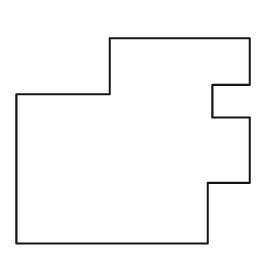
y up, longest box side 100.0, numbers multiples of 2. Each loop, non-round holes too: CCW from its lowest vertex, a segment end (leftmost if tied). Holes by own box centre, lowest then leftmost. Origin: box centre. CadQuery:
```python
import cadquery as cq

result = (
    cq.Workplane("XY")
    .moveTo(-50.0, -44.0)
    .lineTo(32.0, -44.0)
    .lineTo(32.0, -18.0)
    .lineTo(50.0, -18.0)
    .lineTo(50.0, 10.0)
    .lineTo(34.0, 10.0)
    .lineTo(34.0, 24.0)
    .lineTo(50.0, 24.0)
    .lineTo(50.0, 44.0)
    .lineTo(-10.0, 44.0)
    .lineTo(-10.0, 20.0)
    .lineTo(-50.0, 20.0)
    .close()
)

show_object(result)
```